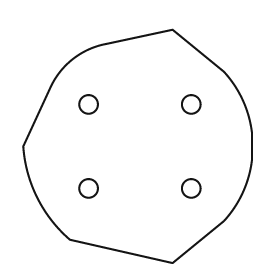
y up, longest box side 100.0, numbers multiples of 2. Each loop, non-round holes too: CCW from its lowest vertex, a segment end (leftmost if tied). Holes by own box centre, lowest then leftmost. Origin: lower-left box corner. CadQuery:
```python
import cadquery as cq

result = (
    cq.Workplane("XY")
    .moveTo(64.0, 0.0)
    .lineTo(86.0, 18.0)
    .threePointArc((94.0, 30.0), (98.0, 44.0))
    .lineTo(98.0, 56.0)
    .threePointArc((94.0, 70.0), (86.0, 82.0))
    .lineTo(64.0, 100.0)
    .lineTo(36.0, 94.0)
    .threePointArc((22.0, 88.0), (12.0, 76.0))
    .lineTo(0.0, 50.0)
    .threePointArc((6.0, 28.0), (20.0, 10.0))
    .close()
    .moveTo(28.0, 32.0)
    .circle(4.0)
    .moveTo(72.0, 32.0)
    .circle(4.0)
    .moveTo(28.0, 68.0)
    .circle(4.0)
    .moveTo(72.0, 68.0)
    .circle(4.0)
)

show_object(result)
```